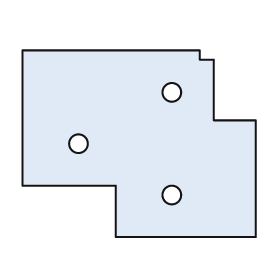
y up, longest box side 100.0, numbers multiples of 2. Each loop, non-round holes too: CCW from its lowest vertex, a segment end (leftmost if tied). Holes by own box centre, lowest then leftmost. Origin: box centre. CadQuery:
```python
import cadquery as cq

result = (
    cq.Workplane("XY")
    .moveTo(-10.0, -40.0)
    .lineTo(50.0, -40.0)
    .lineTo(50.0, 10.0)
    .lineTo(32.0, 10.0)
    .lineTo(32.0, 36.0)
    .lineTo(26.0, 36.0)
    .lineTo(26.0, 40.0)
    .lineTo(-50.0, 40.0)
    .lineTo(-50.0, -18.0)
    .lineTo(-10.0, -18.0)
    .close()
    .moveTo(14.0, -22.0)
    .circle(4.0)
    .moveTo(-26.0, 0.0)
    .circle(4.0)
    .moveTo(14.0, 22.0)
    .circle(4.0)
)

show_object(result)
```